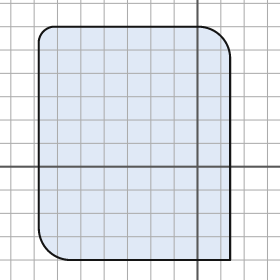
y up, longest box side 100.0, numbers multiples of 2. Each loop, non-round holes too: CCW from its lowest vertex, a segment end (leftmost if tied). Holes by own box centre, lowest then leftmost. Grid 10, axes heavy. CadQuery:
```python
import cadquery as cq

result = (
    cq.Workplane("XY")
    .moveTo(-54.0, -40.0)
    .lineTo(14.0, -40.0)
    .lineTo(14.0, 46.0)
    .threePointArc((10.0, 56.0), (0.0, 60.0))
    .lineTo(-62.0, 60.0)
    .threePointArc((-66.0, 58.0), (-68.0, 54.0))
    .lineTo(-68.0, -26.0)
    .threePointArc((-64.0, -36.0), (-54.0, -40.0))
    .close()
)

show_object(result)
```